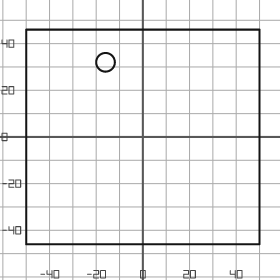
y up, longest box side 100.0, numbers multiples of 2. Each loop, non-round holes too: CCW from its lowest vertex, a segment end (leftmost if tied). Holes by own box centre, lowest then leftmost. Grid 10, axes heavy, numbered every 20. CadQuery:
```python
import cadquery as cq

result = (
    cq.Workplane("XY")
    .moveTo(-50.0, -46.0)
    .lineTo(50.0, -46.0)
    .lineTo(50.0, 46.0)
    .lineTo(-50.0, 46.0)
    .close()
    .moveTo(-16.0, 32.0)
    .circle(4.0)
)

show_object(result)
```